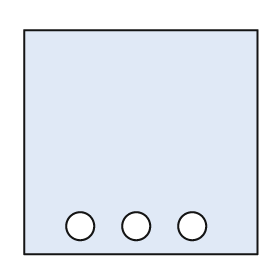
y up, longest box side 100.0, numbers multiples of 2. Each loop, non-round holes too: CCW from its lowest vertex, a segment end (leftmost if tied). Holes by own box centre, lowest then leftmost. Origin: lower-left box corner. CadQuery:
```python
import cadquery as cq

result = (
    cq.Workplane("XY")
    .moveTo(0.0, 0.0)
    .lineTo(100.0, 0.0)
    .lineTo(100.0, 96.0)
    .lineTo(0.0, 96.0)
    .close()
    .moveTo(24.0, 12.0)
    .circle(6.0)
    .moveTo(48.0, 12.0)
    .circle(6.0)
    .moveTo(72.0, 12.0)
    .circle(6.0)
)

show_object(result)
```